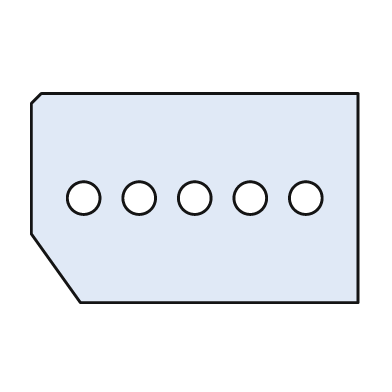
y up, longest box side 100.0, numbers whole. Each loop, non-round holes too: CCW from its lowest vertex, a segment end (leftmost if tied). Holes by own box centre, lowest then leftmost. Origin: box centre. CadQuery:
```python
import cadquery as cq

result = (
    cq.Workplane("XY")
    .moveTo(-35.0, -32.0)
    .lineTo(50.0, -32.0)
    .lineTo(50.0, 32.0)
    .lineTo(-47.0, 32.0)
    .lineTo(-50.0, 29.0)
    .lineTo(-50.0, -11.0)
    .close()
    .moveTo(-34.0, 0.0)
    .circle(5.0)
    .moveTo(-17.0, 0.0)
    .circle(5.0)
    .moveTo(0.0, 0.0)
    .circle(5.0)
    .moveTo(17.0, 0.0)
    .circle(5.0)
    .moveTo(34.0, 0.0)
    .circle(5.0)
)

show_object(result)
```